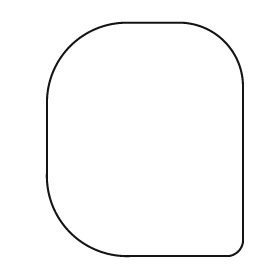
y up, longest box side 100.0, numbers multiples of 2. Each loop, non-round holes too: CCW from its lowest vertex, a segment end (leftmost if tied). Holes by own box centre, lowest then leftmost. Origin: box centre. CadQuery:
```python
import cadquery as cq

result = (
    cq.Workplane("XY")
    .moveTo(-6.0, -50.0)
    .lineTo(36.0, -50.0)
    .threePointArc((40.0, -48.0), (42.0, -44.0))
    .lineTo(42.0, 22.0)
    .threePointArc((34.0, 42.0), (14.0, 50.0))
    .lineTo(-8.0, 50.0)
    .threePointArc((-32.0, 40.0), (-42.0, 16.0))
    .lineTo(-42.0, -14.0)
    .threePointArc((-32.0, -40.0), (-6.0, -50.0))
    .close()
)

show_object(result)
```